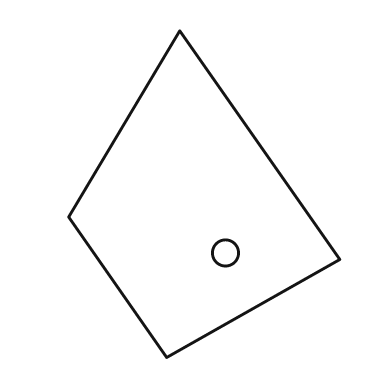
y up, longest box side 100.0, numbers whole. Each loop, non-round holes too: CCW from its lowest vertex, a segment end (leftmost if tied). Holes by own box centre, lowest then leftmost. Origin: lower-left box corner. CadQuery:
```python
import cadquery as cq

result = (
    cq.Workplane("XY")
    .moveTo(30.0, 0.0)
    .lineTo(83.0, 30.0)
    .lineTo(34.0, 100.0)
    .lineTo(0.0, 43.0)
    .close()
    .moveTo(48.0, 32.0)
    .circle(4.0)
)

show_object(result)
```